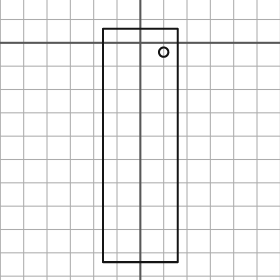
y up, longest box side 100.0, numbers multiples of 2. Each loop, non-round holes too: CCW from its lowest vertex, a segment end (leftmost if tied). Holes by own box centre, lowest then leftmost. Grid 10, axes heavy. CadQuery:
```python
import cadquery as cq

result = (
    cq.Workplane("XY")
    .moveTo(-16.0, -94.0)
    .lineTo(16.0, -94.0)
    .lineTo(16.0, 6.0)
    .lineTo(-16.0, 6.0)
    .close()
    .moveTo(10.0, -4.0)
    .circle(2.0)
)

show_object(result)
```